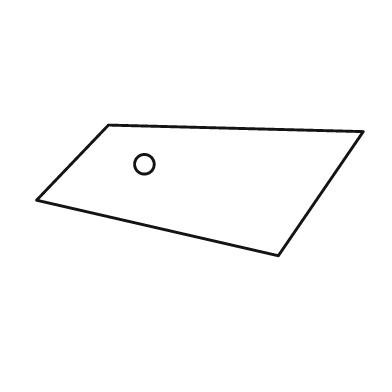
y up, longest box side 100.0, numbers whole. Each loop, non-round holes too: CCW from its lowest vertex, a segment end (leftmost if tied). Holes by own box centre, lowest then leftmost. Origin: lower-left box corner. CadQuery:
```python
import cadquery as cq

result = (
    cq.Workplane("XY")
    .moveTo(74.0, 0.0)
    .lineTo(100.0, 38.0)
    .lineTo(22.0, 40.0)
    .lineTo(0.0, 17.0)
    .close()
    .moveTo(33.0, 28.0)
    .circle(3.0)
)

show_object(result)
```